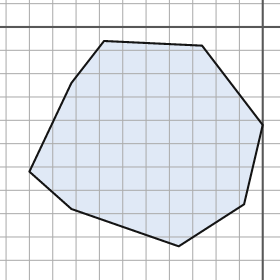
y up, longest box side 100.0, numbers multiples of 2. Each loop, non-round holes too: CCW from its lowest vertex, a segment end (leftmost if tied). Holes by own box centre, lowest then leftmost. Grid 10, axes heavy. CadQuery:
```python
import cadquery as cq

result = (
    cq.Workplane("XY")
    .moveTo(-36.0, -94.0)
    .lineTo(-8.0, -76.0)
    .lineTo(0.0, -42.0)
    .lineTo(-26.0, -8.0)
    .lineTo(-68.0, -6.0)
    .lineTo(-82.0, -24.0)
    .lineTo(-100.0, -62.0)
    .lineTo(-82.0, -78.0)
    .close()
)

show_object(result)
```